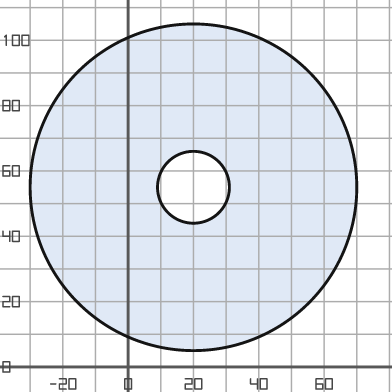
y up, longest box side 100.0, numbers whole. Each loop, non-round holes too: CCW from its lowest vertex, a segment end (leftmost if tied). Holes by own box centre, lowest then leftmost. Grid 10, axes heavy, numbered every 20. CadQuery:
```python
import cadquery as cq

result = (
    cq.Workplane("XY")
    .moveTo(20.0, 55.0)
    .circle(50.0)
    .moveTo(20.0, 55.0)
    .circle(11.0)
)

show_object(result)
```